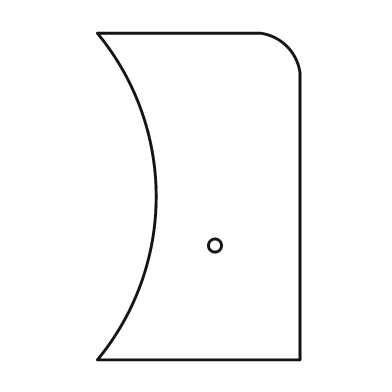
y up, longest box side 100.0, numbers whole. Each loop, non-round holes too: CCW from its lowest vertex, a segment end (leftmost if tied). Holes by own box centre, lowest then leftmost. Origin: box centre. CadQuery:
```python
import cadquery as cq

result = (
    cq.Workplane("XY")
    .moveTo(-31.0, -50.0)
    .lineTo(31.0, -50.0)
    .lineTo(31.0, 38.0)
    .threePointArc((27.0, 46.0), (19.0, 50.0))
    .lineTo(-31.0, 50.0)
    .threePointArc((-13.0, 0.0), (-31.0, -50.0))
    .close()
    .moveTo(5.0, -15.0)
    .circle(2.0)
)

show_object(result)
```